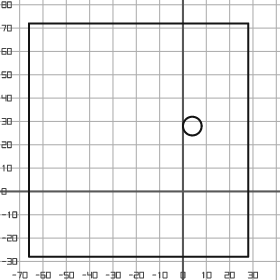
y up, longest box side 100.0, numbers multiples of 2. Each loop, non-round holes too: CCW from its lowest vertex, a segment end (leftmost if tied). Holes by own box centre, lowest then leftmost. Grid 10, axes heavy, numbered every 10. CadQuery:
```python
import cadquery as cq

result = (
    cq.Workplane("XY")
    .moveTo(-66.0, -28.0)
    .lineTo(28.0, -28.0)
    .lineTo(28.0, 72.0)
    .lineTo(-66.0, 72.0)
    .close()
    .moveTo(4.0, 28.0)
    .circle(4.0)
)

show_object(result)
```